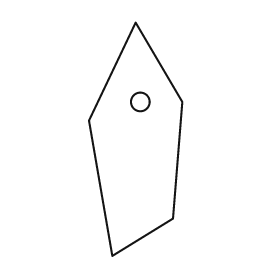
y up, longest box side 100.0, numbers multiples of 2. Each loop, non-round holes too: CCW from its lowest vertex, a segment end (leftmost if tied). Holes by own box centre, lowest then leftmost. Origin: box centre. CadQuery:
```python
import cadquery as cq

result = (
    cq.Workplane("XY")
    .moveTo(-10.0, -50.0)
    .lineTo(16.0, -34.0)
    .lineTo(20.0, 16.0)
    .lineTo(0.0, 50.0)
    .lineTo(-20.0, 8.0)
    .close()
    .moveTo(2.0, 16.0)
    .circle(4.0)
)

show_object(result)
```